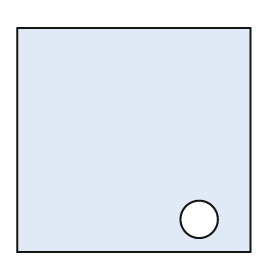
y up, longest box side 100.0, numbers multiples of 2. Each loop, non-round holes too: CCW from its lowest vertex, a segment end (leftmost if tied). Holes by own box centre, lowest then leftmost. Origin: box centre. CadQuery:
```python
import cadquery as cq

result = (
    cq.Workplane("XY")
    .moveTo(-50.0, -48.0)
    .lineTo(50.0, -48.0)
    .lineTo(50.0, 48.0)
    .lineTo(-50.0, 48.0)
    .close()
    .moveTo(28.0, -34.0)
    .circle(8.0)
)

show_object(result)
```